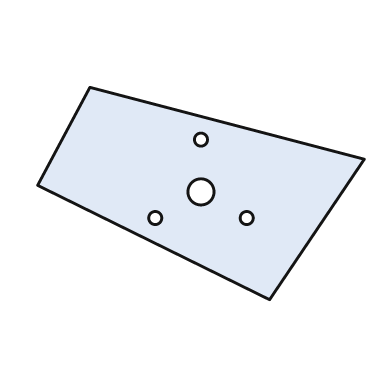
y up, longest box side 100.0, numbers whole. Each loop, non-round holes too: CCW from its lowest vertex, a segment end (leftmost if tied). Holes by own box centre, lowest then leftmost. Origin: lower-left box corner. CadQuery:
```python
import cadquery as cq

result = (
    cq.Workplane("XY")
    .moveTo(71.0, 0.0)
    .lineTo(100.0, 43.0)
    .lineTo(16.0, 65.0)
    .lineTo(0.0, 35.0)
    .close()
    .moveTo(36.0, 25.0)
    .circle(2.0)
    .moveTo(64.0, 25.0)
    .circle(2.0)
    .moveTo(50.0, 33.0)
    .circle(4.0)
    .moveTo(50.0, 49.0)
    .circle(2.0)
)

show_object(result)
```